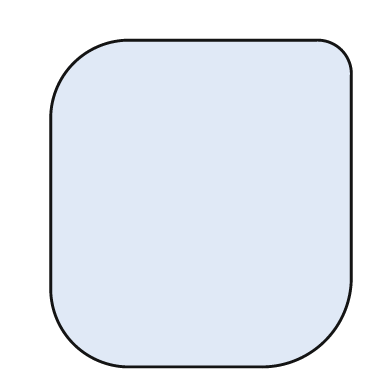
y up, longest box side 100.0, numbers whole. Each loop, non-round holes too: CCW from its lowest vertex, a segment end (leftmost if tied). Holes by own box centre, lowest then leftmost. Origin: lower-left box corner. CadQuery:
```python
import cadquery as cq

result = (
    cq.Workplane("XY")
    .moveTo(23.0, 0.0)
    .lineTo(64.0, 0.0)
    .threePointArc((84.0, 8.0), (92.0, 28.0))
    .lineTo(92.0, 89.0)
    .threePointArc((89.0, 97.0), (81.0, 100.0))
    .lineTo(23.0, 100.0)
    .threePointArc((7.0, 93.0), (0.0, 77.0))
    .lineTo(0.0, 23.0)
    .threePointArc((7.0, 7.0), (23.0, 0.0))
    .close()
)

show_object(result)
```